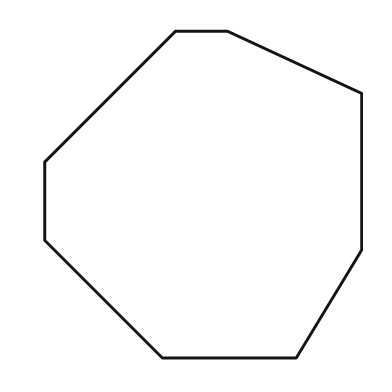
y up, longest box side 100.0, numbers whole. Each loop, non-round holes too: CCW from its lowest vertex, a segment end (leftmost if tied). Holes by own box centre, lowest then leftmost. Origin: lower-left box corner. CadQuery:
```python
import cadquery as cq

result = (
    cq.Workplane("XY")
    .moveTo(36.0, 0.0)
    .lineTo(77.0, 0.0)
    .lineTo(97.0, 33.0)
    .lineTo(97.0, 81.0)
    .lineTo(56.0, 100.0)
    .lineTo(40.0, 100.0)
    .lineTo(0.0, 60.0)
    .lineTo(0.0, 36.0)
    .close()
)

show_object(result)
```